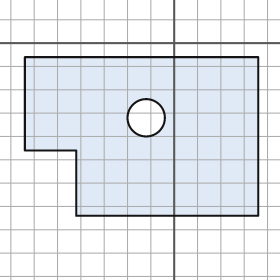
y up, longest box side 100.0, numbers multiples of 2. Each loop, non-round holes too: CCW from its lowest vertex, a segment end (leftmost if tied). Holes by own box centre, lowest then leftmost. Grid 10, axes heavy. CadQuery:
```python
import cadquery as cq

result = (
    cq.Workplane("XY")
    .moveTo(-42.0, -74.0)
    .lineTo(36.0, -74.0)
    .lineTo(36.0, -6.0)
    .lineTo(-64.0, -6.0)
    .lineTo(-64.0, -46.0)
    .lineTo(-42.0, -46.0)
    .close()
    .moveTo(-12.0, -32.0)
    .circle(8.0)
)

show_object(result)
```